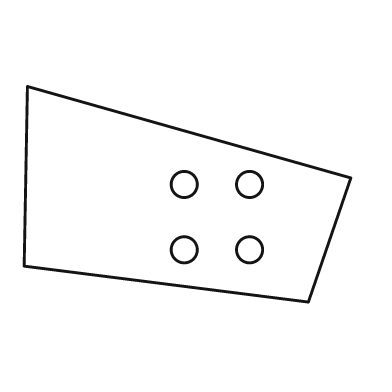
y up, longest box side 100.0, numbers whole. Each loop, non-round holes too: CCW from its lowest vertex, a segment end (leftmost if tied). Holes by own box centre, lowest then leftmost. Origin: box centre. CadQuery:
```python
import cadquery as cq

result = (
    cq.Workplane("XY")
    .moveTo(37.0, -33.0)
    .lineTo(50.0, 5.0)
    .lineTo(-49.0, 33.0)
    .lineTo(-50.0, -22.0)
    .close()
    .moveTo(-1.0, -17.0)
    .circle(4.0)
    .moveTo(19.0, -17.0)
    .circle(4.0)
    .moveTo(-1.0, 3.0)
    .circle(4.0)
    .moveTo(19.0, 3.0)
    .circle(4.0)
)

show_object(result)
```